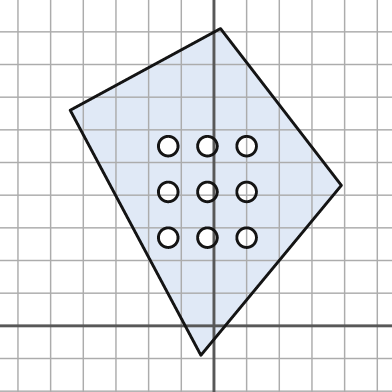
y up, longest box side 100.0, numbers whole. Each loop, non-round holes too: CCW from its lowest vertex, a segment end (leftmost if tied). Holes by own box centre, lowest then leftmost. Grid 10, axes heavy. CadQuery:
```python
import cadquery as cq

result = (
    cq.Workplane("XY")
    .moveTo(-4.0, -9.0)
    .lineTo(39.0, 43.0)
    .lineTo(2.0, 91.0)
    .lineTo(-44.0, 66.0)
    .close()
    .moveTo(-14.0, 27.0)
    .circle(3.0)
    .moveTo(-2.0, 27.0)
    .circle(3.0)
    .moveTo(10.0, 27.0)
    .circle(3.0)
    .moveTo(-14.0, 41.0)
    .circle(3.0)
    .moveTo(-2.0, 41.0)
    .circle(3.0)
    .moveTo(10.0, 41.0)
    .circle(3.0)
    .moveTo(-14.0, 55.0)
    .circle(3.0)
    .moveTo(-2.0, 55.0)
    .circle(3.0)
    .moveTo(10.0, 55.0)
    .circle(3.0)
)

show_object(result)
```